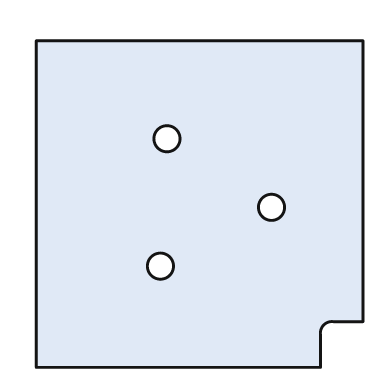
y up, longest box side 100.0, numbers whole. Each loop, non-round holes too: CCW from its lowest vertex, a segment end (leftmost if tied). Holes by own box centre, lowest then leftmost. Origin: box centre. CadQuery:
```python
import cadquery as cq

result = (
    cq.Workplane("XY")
    .moveTo(-50.0, -50.0)
    .lineTo(37.0, -50.0)
    .lineTo(37.0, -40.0)
    .threePointArc((38.0, -37.0), (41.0, -36.0))
    .lineTo(50.0, -36.0)
    .lineTo(50.0, 50.0)
    .lineTo(-50.0, 50.0)
    .close()
    .moveTo(-12.0, -19.0)
    .circle(4.0)
    .moveTo(22.0, -1.0)
    .circle(4.0)
    .moveTo(-10.0, 20.0)
    .circle(4.0)
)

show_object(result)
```